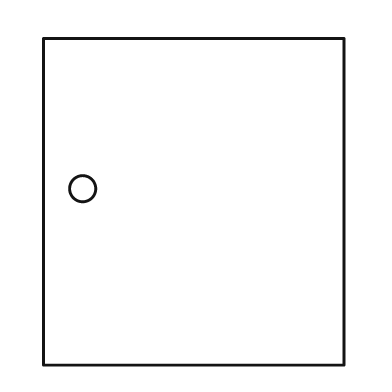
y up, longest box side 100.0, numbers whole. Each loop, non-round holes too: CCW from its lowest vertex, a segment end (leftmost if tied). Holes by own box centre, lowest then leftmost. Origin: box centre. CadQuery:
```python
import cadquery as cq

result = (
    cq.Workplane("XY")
    .moveTo(-46.0, -50.0)
    .lineTo(46.0, -50.0)
    .lineTo(46.0, 50.0)
    .lineTo(-46.0, 50.0)
    .close()
    .moveTo(-34.0, 4.0)
    .circle(4.0)
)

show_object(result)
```